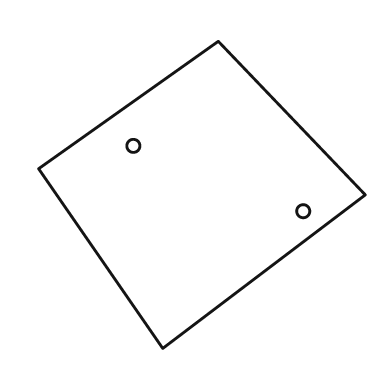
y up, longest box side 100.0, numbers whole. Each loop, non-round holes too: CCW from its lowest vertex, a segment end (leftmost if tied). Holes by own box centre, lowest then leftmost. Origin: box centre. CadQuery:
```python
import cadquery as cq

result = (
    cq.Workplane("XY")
    .moveTo(-12.0, -47.0)
    .lineTo(50.0, 0.0)
    .lineTo(5.0, 47.0)
    .lineTo(-50.0, 8.0)
    .close()
    .moveTo(31.0, -5.0)
    .circle(2.0)
    .moveTo(-21.0, 15.0)
    .circle(2.0)
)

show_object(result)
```